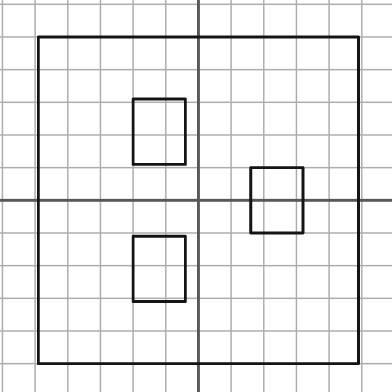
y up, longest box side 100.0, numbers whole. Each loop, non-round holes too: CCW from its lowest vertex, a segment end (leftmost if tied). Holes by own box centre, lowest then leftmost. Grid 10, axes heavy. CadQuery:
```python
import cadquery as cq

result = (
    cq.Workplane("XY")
    .moveTo(-49.0, -50.0)
    .lineTo(49.0, -50.0)
    .lineTo(49.0, 50.0)
    .lineTo(-49.0, 50.0)
    .close()
    .moveTo(-20.0, -31.0)
    .lineTo(-4.0, -31.0)
    .lineTo(-4.0, -11.0)
    .lineTo(-20.0, -11.0)
    .close()
    .moveTo(16.0, -10.0)
    .lineTo(32.0, -10.0)
    .lineTo(32.0, 10.0)
    .lineTo(16.0, 10.0)
    .close()
    .moveTo(-20.0, 11.0)
    .lineTo(-4.0, 11.0)
    .lineTo(-4.0, 31.0)
    .lineTo(-20.0, 31.0)
    .close()
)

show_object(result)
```